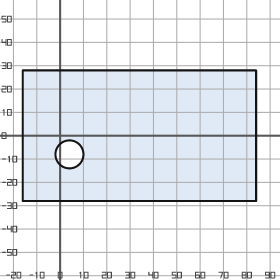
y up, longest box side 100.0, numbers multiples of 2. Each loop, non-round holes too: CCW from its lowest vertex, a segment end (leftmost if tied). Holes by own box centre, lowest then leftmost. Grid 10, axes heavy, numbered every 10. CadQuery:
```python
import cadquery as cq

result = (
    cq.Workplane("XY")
    .moveTo(-16.0, -28.0)
    .lineTo(84.0, -28.0)
    .lineTo(84.0, 28.0)
    .lineTo(-16.0, 28.0)
    .close()
    .moveTo(4.0, -8.0)
    .circle(6.0)
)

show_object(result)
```